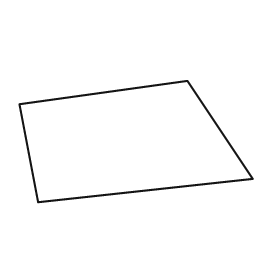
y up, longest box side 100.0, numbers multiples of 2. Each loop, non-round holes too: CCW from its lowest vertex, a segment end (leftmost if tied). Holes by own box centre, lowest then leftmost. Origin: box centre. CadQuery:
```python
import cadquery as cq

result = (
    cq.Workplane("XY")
    .moveTo(-42.0, -26.0)
    .lineTo(50.0, -16.0)
    .lineTo(22.0, 26.0)
    .lineTo(-50.0, 16.0)
    .close()
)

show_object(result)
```